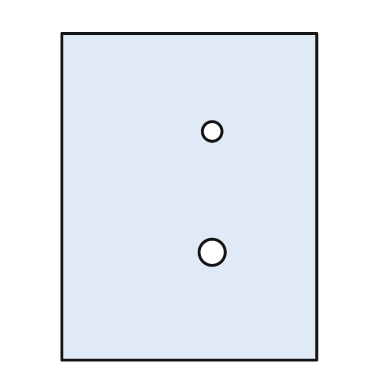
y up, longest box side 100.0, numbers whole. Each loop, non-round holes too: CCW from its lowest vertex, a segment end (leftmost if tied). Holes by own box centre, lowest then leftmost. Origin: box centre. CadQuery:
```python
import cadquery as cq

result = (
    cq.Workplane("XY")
    .moveTo(-39.0, -50.0)
    .lineTo(39.0, -50.0)
    .lineTo(39.0, 50.0)
    .lineTo(-39.0, 50.0)
    .close()
    .moveTo(7.0, -17.0)
    .circle(4.0)
    .moveTo(7.0, 20.0)
    .circle(3.0)
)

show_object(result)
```